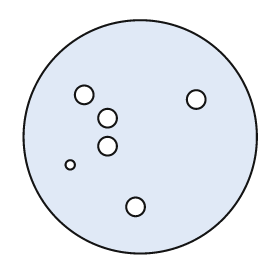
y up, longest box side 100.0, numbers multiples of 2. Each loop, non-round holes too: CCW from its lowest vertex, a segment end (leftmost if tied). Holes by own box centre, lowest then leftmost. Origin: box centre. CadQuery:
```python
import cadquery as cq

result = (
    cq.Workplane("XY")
    .moveTo(0.0, 0.0)
    .circle(50.0)
    .moveTo(-2.0, -30.0)
    .circle(4.0)
    .moveTo(-30.0, -12.0)
    .circle(2.0)
    .moveTo(-14.0, -4.0)
    .circle(4.0)
    .moveTo(-14.0, 8.0)
    .circle(4.0)
    .moveTo(24.0, 16.0)
    .circle(4.0)
    .moveTo(-24.0, 18.0)
    .circle(4.0)
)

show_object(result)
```